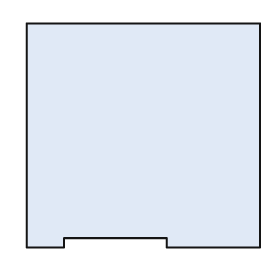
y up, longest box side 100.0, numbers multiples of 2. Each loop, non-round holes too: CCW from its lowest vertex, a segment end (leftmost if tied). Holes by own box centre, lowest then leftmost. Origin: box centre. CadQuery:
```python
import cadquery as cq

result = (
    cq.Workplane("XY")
    .moveTo(-50.0, -48.0)
    .lineTo(-34.0, -48.0)
    .lineTo(-34.0, -44.0)
    .lineTo(10.0, -44.0)
    .lineTo(10.0, -48.0)
    .lineTo(50.0, -48.0)
    .lineTo(50.0, 48.0)
    .lineTo(-50.0, 48.0)
    .close()
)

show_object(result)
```